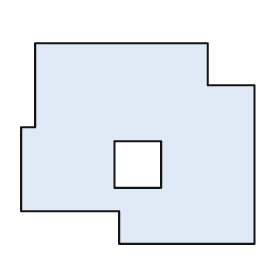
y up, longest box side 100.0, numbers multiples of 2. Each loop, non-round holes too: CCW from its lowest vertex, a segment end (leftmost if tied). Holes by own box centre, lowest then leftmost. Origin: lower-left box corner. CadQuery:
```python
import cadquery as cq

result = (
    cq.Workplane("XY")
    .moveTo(42.0, 0.0)
    .lineTo(100.0, 0.0)
    .lineTo(100.0, 68.0)
    .lineTo(80.0, 68.0)
    .lineTo(80.0, 86.0)
    .lineTo(6.0, 86.0)
    .lineTo(6.0, 50.0)
    .lineTo(0.0, 50.0)
    .lineTo(0.0, 14.0)
    .lineTo(42.0, 14.0)
    .close()
    .moveTo(40.0, 24.0)
    .lineTo(60.0, 24.0)
    .lineTo(60.0, 44.0)
    .lineTo(40.0, 44.0)
    .close()
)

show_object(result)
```